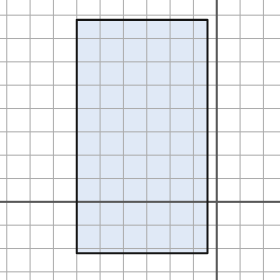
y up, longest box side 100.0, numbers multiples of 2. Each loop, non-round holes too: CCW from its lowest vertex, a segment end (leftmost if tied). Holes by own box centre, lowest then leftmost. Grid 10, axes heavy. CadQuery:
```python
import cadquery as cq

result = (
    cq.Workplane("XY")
    .moveTo(-60.0, -22.0)
    .lineTo(-4.0, -22.0)
    .lineTo(-4.0, 78.0)
    .lineTo(-60.0, 78.0)
    .close()
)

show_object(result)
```